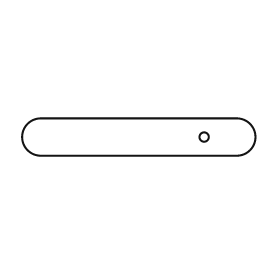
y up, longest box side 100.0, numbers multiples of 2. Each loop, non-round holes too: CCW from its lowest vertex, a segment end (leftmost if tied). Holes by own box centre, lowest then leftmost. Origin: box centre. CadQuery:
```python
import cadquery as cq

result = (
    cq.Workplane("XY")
    .moveTo(-42.0, -8.0)
    .lineTo(42.0, -8.0)
    .threePointArc((50.0, 0.0), (42.0, 8.0))
    .lineTo(-42.0, 8.0)
    .threePointArc((-50.0, 0.0), (-42.0, -8.0))
    .close()
    .moveTo(28.0, 0.0)
    .circle(2.0)
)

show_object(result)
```